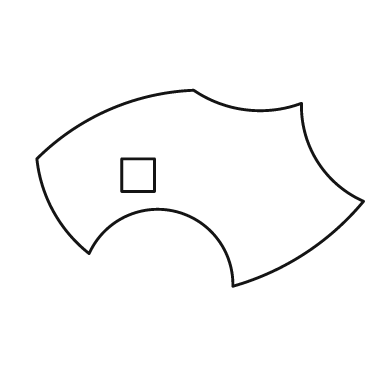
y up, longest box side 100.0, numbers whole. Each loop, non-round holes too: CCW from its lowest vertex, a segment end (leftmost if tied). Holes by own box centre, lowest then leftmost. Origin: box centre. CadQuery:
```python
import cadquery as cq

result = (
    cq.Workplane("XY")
    .moveTo(10.0, -30.0)
    .threePointArc((32.0, -20.0), (50.0, -4.0))
    .threePointArc((36.0, 8.0), (31.0, 26.0))
    .threePointArc((14.0, 24.0), (-2.0, 30.0))
    .threePointArc((-28.0, 24.0), (-50.0, 9.0))
    .threePointArc((-45.0, -7.0), (-34.0, -20.0))
    .threePointArc((-8.0, -7.0), (10.0, -30.0))
    .close()
    .moveTo(-24.0, -1.0)
    .lineTo(-14.0, -1.0)
    .lineTo(-14.0, 9.0)
    .lineTo(-24.0, 9.0)
    .close()
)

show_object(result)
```